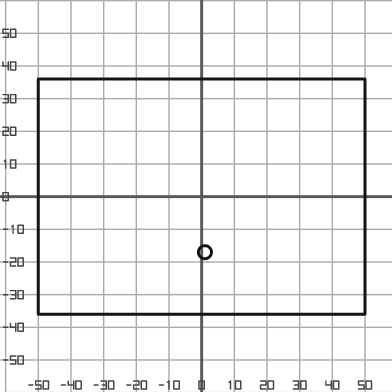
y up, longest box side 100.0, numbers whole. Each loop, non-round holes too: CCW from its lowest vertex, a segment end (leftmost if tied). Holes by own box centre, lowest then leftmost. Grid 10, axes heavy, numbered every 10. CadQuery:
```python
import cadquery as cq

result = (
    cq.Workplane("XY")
    .moveTo(-50.0, -36.0)
    .lineTo(50.0, -36.0)
    .lineTo(50.0, 36.0)
    .lineTo(-50.0, 36.0)
    .close()
    .moveTo(1.0, -17.0)
    .circle(2.0)
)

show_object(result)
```